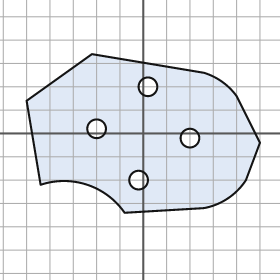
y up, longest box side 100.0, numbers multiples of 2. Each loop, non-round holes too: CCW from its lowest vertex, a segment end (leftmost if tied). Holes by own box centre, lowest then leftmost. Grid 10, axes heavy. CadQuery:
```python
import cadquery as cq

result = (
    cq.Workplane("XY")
    .moveTo(-8.0, -34.0)
    .lineTo(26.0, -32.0)
    .threePointArc((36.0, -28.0), (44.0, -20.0))
    .lineTo(50.0, -4.0)
    .lineTo(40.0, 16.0)
    .threePointArc((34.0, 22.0), (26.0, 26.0))
    .lineTo(-22.0, 34.0)
    .lineTo(-50.0, 14.0)
    .lineTo(-44.0, -22.0)
    .threePointArc((-24.0, -22.0), (-8.0, -34.0))
    .close()
    .moveTo(-2.0, -20.0)
    .circle(4.0)
    .moveTo(20.0, -2.0)
    .circle(4.0)
    .moveTo(-20.0, 2.0)
    .circle(4.0)
    .moveTo(2.0, 20.0)
    .circle(4.0)
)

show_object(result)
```